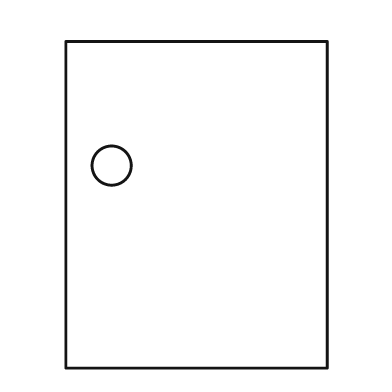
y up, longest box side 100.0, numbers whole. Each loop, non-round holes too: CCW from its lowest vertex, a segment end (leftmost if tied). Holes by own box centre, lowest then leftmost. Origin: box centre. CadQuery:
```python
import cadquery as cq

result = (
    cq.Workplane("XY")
    .moveTo(-40.0, -50.0)
    .lineTo(40.0, -50.0)
    .lineTo(40.0, 50.0)
    .lineTo(-40.0, 50.0)
    .close()
    .moveTo(-26.0, 12.0)
    .circle(6.0)
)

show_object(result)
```